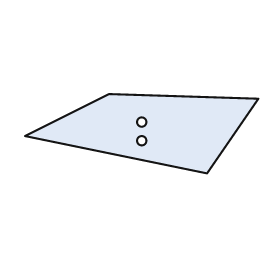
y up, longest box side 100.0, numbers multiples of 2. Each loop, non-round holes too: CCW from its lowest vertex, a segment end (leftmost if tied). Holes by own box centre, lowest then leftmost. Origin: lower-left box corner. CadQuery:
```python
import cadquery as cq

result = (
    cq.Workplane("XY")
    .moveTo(78.0, 0.0)
    .lineTo(100.0, 32.0)
    .lineTo(36.0, 34.0)
    .lineTo(0.0, 16.0)
    .close()
    .moveTo(50.0, 14.0)
    .circle(2.0)
    .moveTo(50.0, 22.0)
    .circle(2.0)
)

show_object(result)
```